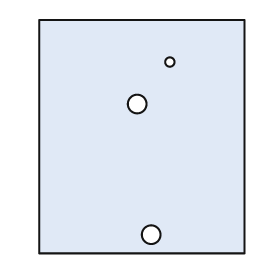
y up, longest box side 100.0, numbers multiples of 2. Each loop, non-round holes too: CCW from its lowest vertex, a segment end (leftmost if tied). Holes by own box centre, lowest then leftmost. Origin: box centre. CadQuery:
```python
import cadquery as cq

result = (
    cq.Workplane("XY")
    .moveTo(-44.0, -50.0)
    .lineTo(44.0, -50.0)
    .lineTo(44.0, 50.0)
    .lineTo(-44.0, 50.0)
    .close()
    .moveTo(4.0, -42.0)
    .circle(4.0)
    .moveTo(-2.0, 14.0)
    .circle(4.0)
    .moveTo(12.0, 32.0)
    .circle(2.0)
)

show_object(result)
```